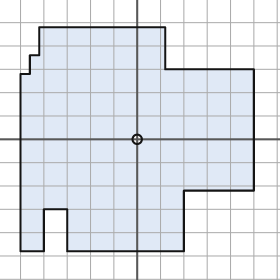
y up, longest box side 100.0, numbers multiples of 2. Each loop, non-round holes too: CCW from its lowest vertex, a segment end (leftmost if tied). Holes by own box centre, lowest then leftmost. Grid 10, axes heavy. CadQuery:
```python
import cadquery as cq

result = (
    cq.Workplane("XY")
    .moveTo(-50.0, -48.0)
    .lineTo(-40.0, -48.0)
    .lineTo(-40.0, -30.0)
    .lineTo(-30.0, -30.0)
    .lineTo(-30.0, -48.0)
    .lineTo(20.0, -48.0)
    .lineTo(20.0, -22.0)
    .lineTo(50.0, -22.0)
    .lineTo(50.0, 30.0)
    .lineTo(12.0, 30.0)
    .lineTo(12.0, 48.0)
    .lineTo(-42.0, 48.0)
    .lineTo(-42.0, 36.0)
    .lineTo(-46.0, 36.0)
    .lineTo(-46.0, 28.0)
    .lineTo(-50.0, 28.0)
    .close()
    .moveTo(0.0, 0.0)
    .circle(2.0)
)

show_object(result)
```